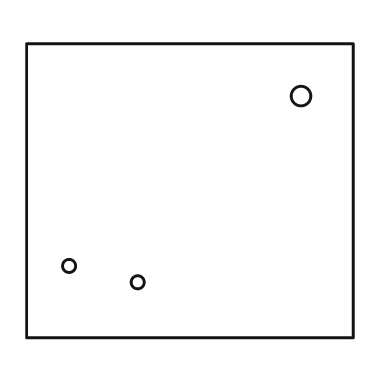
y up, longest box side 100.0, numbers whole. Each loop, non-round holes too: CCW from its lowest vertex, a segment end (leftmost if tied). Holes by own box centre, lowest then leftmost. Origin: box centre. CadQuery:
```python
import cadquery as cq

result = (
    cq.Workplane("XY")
    .moveTo(-50.0, -45.0)
    .lineTo(50.0, -45.0)
    .lineTo(50.0, 45.0)
    .lineTo(-50.0, 45.0)
    .close()
    .moveTo(-16.0, -28.0)
    .circle(2.0)
    .moveTo(-37.0, -23.0)
    .circle(2.0)
    .moveTo(34.0, 29.0)
    .circle(3.0)
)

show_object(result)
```